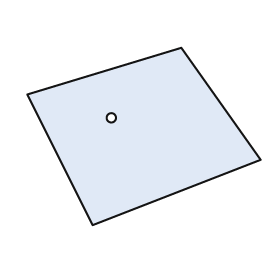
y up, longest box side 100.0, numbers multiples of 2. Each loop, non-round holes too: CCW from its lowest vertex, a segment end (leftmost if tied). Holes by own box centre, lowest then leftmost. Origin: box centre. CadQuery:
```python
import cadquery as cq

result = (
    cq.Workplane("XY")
    .moveTo(-22.0, -38.0)
    .lineTo(50.0, -10.0)
    .lineTo(16.0, 38.0)
    .lineTo(-50.0, 18.0)
    .close()
    .moveTo(-14.0, 8.0)
    .circle(2.0)
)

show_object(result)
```